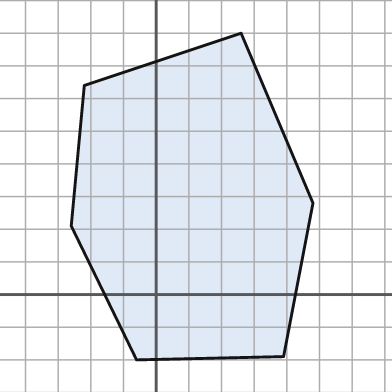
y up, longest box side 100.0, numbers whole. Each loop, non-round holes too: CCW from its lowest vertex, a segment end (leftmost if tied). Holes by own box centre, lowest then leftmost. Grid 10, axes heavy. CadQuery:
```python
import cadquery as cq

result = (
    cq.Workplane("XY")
    .moveTo(-6.0, -20.0)
    .lineTo(39.0, -19.0)
    .lineTo(48.0, 28.0)
    .lineTo(26.0, 80.0)
    .lineTo(-22.0, 64.0)
    .lineTo(-26.0, 21.0)
    .close()
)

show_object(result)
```